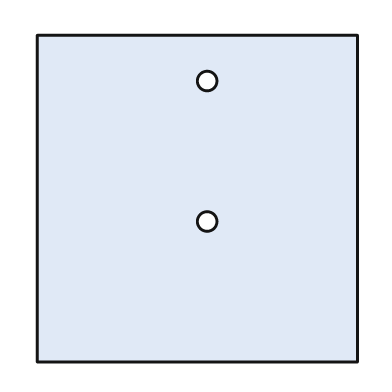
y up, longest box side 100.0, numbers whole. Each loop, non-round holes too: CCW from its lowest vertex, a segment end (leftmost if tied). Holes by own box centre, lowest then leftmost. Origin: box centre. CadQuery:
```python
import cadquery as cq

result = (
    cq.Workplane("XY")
    .moveTo(-49.0, -50.0)
    .lineTo(49.0, -50.0)
    .lineTo(49.0, 50.0)
    .lineTo(-49.0, 50.0)
    .close()
    .moveTo(3.0, -7.0)
    .circle(3.0)
    .moveTo(3.0, 36.0)
    .circle(3.0)
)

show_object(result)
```